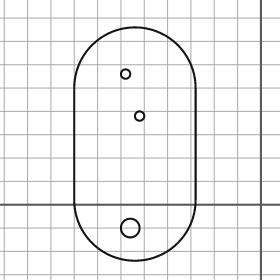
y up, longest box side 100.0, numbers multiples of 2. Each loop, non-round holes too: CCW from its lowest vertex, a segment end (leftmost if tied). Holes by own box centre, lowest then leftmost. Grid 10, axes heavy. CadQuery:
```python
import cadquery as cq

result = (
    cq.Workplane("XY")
    .moveTo(-80.0, 2.0)
    .threePointArc((-54.0, -24.0), (-28.0, 2.0))
    .lineTo(-28.0, 50.0)
    .threePointArc((-54.0, 76.0), (-80.0, 50.0))
    .close()
    .moveTo(-56.0, -10.0)
    .circle(4.0)
    .moveTo(-52.0, 38.0)
    .circle(2.0)
    .moveTo(-58.0, 56.0)
    .circle(2.0)
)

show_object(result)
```